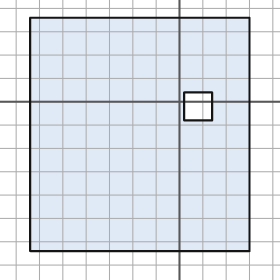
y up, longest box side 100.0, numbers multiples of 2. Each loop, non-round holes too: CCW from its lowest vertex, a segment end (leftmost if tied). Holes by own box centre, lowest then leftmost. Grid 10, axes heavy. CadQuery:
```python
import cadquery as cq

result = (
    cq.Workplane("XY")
    .moveTo(-64.0, -64.0)
    .lineTo(30.0, -64.0)
    .lineTo(30.0, 36.0)
    .lineTo(-64.0, 36.0)
    .close()
    .moveTo(2.0, -8.0)
    .lineTo(14.0, -8.0)
    .lineTo(14.0, 4.0)
    .lineTo(2.0, 4.0)
    .close()
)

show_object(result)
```